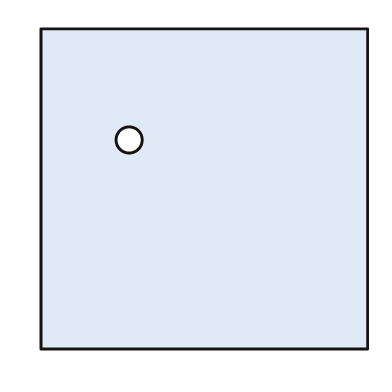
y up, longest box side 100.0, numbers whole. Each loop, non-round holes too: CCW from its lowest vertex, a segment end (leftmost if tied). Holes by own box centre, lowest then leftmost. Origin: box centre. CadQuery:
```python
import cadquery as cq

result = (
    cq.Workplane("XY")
    .moveTo(-50.0, -49.0)
    .lineTo(50.0, -49.0)
    .lineTo(50.0, 49.0)
    .lineTo(-50.0, 49.0)
    .close()
    .moveTo(-23.0, 15.0)
    .circle(4.0)
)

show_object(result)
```